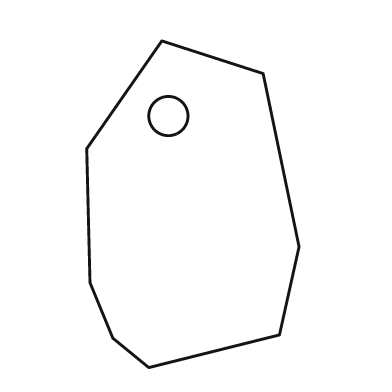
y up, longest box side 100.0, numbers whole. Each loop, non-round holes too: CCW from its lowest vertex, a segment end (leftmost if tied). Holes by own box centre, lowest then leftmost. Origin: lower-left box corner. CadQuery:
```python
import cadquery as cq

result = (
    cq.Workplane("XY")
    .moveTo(19.0, 0.0)
    .lineTo(59.0, 10.0)
    .lineTo(65.0, 37.0)
    .lineTo(54.0, 90.0)
    .lineTo(23.0, 100.0)
    .lineTo(0.0, 67.0)
    .lineTo(1.0, 26.0)
    .lineTo(8.0, 9.0)
    .close()
    .moveTo(25.0, 77.0)
    .circle(6.0)
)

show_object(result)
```